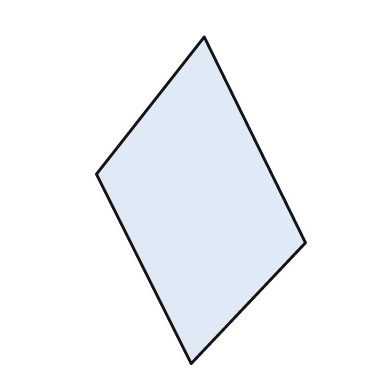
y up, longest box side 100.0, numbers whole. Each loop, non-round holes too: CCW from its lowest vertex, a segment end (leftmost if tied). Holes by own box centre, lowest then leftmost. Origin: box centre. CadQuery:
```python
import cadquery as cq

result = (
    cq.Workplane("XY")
    .moveTo(-3.0, -50.0)
    .lineTo(32.0, -13.0)
    .lineTo(1.0, 50.0)
    .lineTo(-32.0, 8.0)
    .close()
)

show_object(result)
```